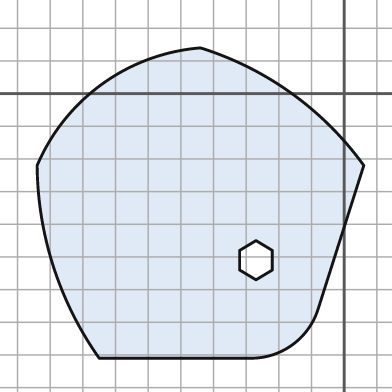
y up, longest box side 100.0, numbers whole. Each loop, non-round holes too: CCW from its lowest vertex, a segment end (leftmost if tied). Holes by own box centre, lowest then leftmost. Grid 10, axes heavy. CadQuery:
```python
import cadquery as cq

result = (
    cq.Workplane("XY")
    .moveTo(-75.0, -81.0)
    .lineTo(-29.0, -81.0)
    .threePointArc((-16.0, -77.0), (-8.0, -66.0))
    .lineTo(6.0, -22.0)
    .threePointArc((-16.0, 0.0), (-44.0, 14.0))
    .threePointArc((-74.0, 3.0), (-94.0, -22.0))
    .threePointArc((-89.0, -53.0), (-75.0, -81.0))
    .close()
    .moveTo(-27.0, -57.0)
    .lineTo(-22.0, -54.0)
    .lineTo(-22.0, -48.0)
    .lineTo(-27.0, -45.0)
    .lineTo(-32.0, -48.0)
    .lineTo(-32.0, -54.0)
    .close()
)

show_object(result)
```